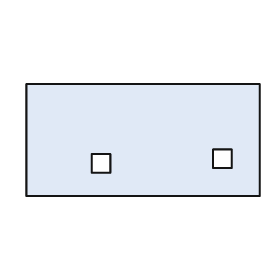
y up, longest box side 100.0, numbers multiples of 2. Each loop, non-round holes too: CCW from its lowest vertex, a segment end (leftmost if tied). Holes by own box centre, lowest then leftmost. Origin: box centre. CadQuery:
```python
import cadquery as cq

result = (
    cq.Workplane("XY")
    .moveTo(-50.0, -24.0)
    .lineTo(50.0, -24.0)
    .lineTo(50.0, 24.0)
    .lineTo(-50.0, 24.0)
    .close()
    .moveTo(-22.0, -14.0)
    .lineTo(-14.0, -14.0)
    .lineTo(-14.0, -6.0)
    .lineTo(-22.0, -6.0)
    .close()
    .moveTo(30.0, -12.0)
    .lineTo(38.0, -12.0)
    .lineTo(38.0, -4.0)
    .lineTo(30.0, -4.0)
    .close()
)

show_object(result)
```